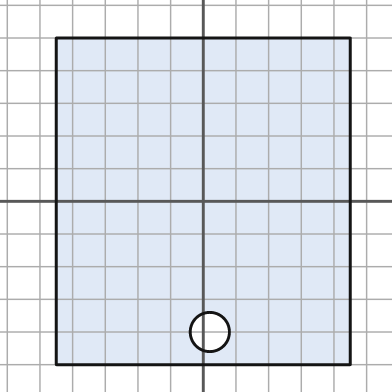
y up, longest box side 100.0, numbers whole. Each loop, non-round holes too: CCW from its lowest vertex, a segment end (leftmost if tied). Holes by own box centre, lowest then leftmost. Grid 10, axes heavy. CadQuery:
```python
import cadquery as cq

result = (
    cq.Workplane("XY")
    .moveTo(-45.0, -50.0)
    .lineTo(45.0, -50.0)
    .lineTo(45.0, 50.0)
    .lineTo(-45.0, 50.0)
    .close()
    .moveTo(2.0, -40.0)
    .circle(6.0)
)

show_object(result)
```